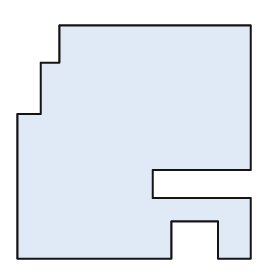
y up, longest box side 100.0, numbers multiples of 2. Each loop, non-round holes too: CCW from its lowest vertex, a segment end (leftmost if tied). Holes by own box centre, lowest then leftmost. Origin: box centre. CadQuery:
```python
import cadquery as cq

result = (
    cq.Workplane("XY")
    .moveTo(-50.0, -50.0)
    .lineTo(16.0, -50.0)
    .lineTo(16.0, -34.0)
    .lineTo(36.0, -34.0)
    .lineTo(36.0, -50.0)
    .lineTo(50.0, -50.0)
    .lineTo(50.0, -24.0)
    .lineTo(8.0, -24.0)
    .lineTo(8.0, -12.0)
    .lineTo(50.0, -12.0)
    .lineTo(50.0, 50.0)
    .lineTo(-32.0, 50.0)
    .lineTo(-32.0, 34.0)
    .lineTo(-40.0, 34.0)
    .lineTo(-40.0, 12.0)
    .lineTo(-50.0, 12.0)
    .close()
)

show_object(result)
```